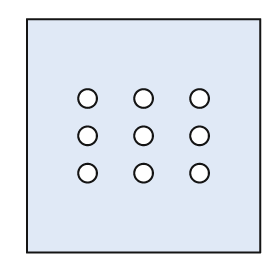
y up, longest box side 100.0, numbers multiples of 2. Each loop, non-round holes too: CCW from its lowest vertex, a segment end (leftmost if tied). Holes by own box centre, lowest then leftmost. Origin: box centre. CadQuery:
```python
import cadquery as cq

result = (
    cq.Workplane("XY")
    .moveTo(-50.0, -50.0)
    .lineTo(50.0, -50.0)
    .lineTo(50.0, 50.0)
    .lineTo(-50.0, 50.0)
    .close()
    .moveTo(-24.0, -16.0)
    .circle(4.0)
    .moveTo(0.0, -16.0)
    .circle(4.0)
    .moveTo(24.0, -16.0)
    .circle(4.0)
    .moveTo(-24.0, 0.0)
    .circle(4.0)
    .moveTo(0.0, 0.0)
    .circle(4.0)
    .moveTo(24.0, 0.0)
    .circle(4.0)
    .moveTo(-24.0, 16.0)
    .circle(4.0)
    .moveTo(0.0, 16.0)
    .circle(4.0)
    .moveTo(24.0, 16.0)
    .circle(4.0)
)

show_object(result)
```